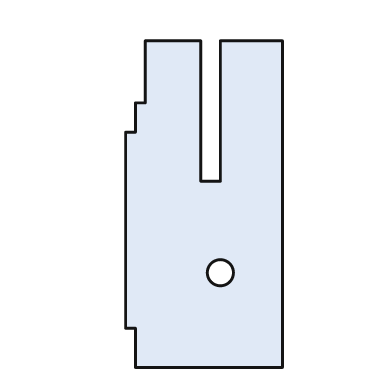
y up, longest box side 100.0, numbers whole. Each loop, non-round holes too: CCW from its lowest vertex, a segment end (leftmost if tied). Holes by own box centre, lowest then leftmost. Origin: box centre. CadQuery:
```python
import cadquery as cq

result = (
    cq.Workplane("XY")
    .moveTo(-21.0, -50.0)
    .lineTo(24.0, -50.0)
    .lineTo(24.0, 50.0)
    .lineTo(5.0, 50.0)
    .lineTo(5.0, 7.0)
    .lineTo(-1.0, 7.0)
    .lineTo(-1.0, 50.0)
    .lineTo(-18.0, 50.0)
    .lineTo(-18.0, 31.0)
    .lineTo(-21.0, 31.0)
    .lineTo(-21.0, 22.0)
    .lineTo(-24.0, 22.0)
    .lineTo(-24.0, -38.0)
    .lineTo(-21.0, -38.0)
    .close()
    .moveTo(5.0, -21.0)
    .circle(4.0)
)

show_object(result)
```